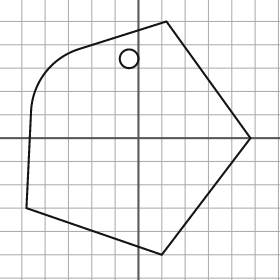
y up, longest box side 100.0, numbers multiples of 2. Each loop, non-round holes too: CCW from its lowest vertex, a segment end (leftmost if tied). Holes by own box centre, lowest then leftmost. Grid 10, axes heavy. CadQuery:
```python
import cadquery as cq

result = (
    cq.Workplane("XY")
    .moveTo(10.0, -50.0)
    .lineTo(48.0, 0.0)
    .lineTo(12.0, 50.0)
    .lineTo(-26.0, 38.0)
    .threePointArc((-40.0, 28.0), (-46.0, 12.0))
    .lineTo(-48.0, -30.0)
    .close()
    .moveTo(-4.0, 34.0)
    .circle(4.0)
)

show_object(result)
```